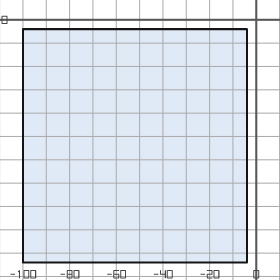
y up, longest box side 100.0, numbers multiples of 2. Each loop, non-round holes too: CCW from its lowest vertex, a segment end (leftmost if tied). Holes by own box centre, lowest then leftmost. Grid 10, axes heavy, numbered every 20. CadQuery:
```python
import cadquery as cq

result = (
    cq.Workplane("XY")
    .moveTo(-100.0, -104.0)
    .lineTo(-4.0, -104.0)
    .lineTo(-4.0, -4.0)
    .lineTo(-100.0, -4.0)
    .close()
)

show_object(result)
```